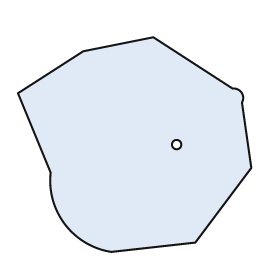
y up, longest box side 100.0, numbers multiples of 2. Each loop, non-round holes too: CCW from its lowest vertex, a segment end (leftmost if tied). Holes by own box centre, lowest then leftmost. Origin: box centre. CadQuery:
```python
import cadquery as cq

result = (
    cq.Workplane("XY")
    .moveTo(-10.0, -46.0)
    .lineTo(26.0, -42.0)
    .lineTo(50.0, -10.0)
    .lineTo(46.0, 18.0)
    .threePointArc((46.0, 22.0), (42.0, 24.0))
    .lineTo(8.0, 46.0)
    .lineTo(-22.0, 40.0)
    .lineTo(-50.0, 22.0)
    .lineTo(-36.0, -12.0)
    .threePointArc((-30.0, -34.0), (-10.0, -46.0))
    .close()
    .moveTo(18.0, 0.0)
    .circle(2.0)
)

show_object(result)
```